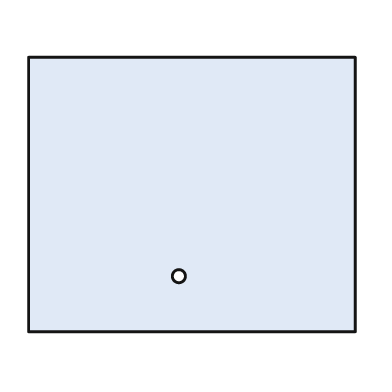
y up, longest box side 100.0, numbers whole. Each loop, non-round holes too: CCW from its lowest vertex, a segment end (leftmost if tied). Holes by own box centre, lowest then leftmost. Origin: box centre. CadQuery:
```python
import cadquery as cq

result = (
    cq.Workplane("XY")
    .moveTo(-50.0, -42.0)
    .lineTo(50.0, -42.0)
    .lineTo(50.0, 42.0)
    .lineTo(-50.0, 42.0)
    .close()
    .moveTo(-4.0, -25.0)
    .circle(2.0)
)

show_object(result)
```